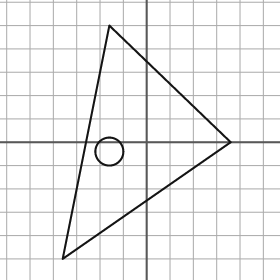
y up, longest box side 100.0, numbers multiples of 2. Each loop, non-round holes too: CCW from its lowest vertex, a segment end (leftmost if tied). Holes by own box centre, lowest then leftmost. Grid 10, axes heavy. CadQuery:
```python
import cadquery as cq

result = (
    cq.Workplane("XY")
    .moveTo(-36.0, -50.0)
    .lineTo(36.0, 0.0)
    .lineTo(-16.0, 50.0)
    .close()
    .moveTo(-16.0, -4.0)
    .circle(6.0)
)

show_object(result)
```